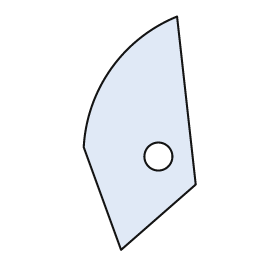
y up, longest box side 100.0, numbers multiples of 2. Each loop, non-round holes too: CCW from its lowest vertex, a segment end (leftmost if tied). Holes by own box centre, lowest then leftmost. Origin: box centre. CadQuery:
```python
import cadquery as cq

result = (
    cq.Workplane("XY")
    .moveTo(-8.0, -50.0)
    .lineTo(24.0, -22.0)
    .lineTo(16.0, 50.0)
    .threePointArc((-12.0, 28.0), (-24.0, -6.0))
    .close()
    .moveTo(8.0, -10.0)
    .circle(6.0)
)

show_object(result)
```